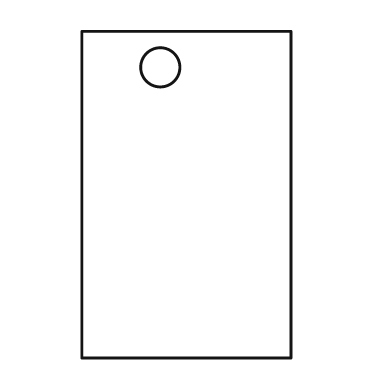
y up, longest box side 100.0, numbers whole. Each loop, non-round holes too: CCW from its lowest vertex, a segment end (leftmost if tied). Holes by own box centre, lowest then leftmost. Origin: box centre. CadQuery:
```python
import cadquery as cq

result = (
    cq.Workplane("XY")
    .moveTo(-32.0, -50.0)
    .lineTo(32.0, -50.0)
    .lineTo(32.0, 50.0)
    .lineTo(-32.0, 50.0)
    .close()
    .moveTo(-8.0, 39.0)
    .circle(6.0)
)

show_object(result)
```